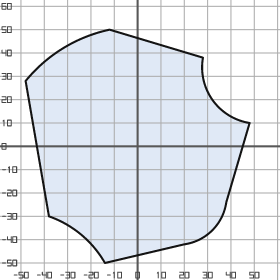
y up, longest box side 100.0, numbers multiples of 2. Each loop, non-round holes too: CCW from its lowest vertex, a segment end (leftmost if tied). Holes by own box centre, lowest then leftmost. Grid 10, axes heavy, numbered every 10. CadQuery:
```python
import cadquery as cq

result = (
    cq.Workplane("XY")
    .moveTo(-14.0, -50.0)
    .lineTo(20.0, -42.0)
    .threePointArc((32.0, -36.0), (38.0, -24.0))
    .lineTo(48.0, 10.0)
    .threePointArc((32.0, 20.0), (28.0, 38.0))
    .lineTo(-12.0, 50.0)
    .threePointArc((-32.0, 42.0), (-48.0, 28.0))
    .lineTo(-38.0, -30.0)
    .threePointArc((-24.0, -38.0), (-14.0, -50.0))
    .close()
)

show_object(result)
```